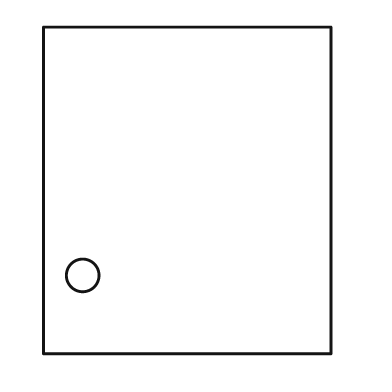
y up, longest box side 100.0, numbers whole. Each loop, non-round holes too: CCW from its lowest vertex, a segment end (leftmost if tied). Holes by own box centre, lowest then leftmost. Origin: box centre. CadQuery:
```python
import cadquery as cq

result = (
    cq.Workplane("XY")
    .moveTo(-44.0, -50.0)
    .lineTo(44.0, -50.0)
    .lineTo(44.0, 50.0)
    .lineTo(-44.0, 50.0)
    .close()
    .moveTo(-32.0, -26.0)
    .circle(5.0)
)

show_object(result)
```